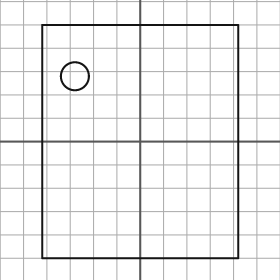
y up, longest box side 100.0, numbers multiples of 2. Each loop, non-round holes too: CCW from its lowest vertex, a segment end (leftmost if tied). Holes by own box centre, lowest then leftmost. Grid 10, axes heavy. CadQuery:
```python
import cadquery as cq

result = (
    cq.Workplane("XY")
    .moveTo(-42.0, -50.0)
    .lineTo(42.0, -50.0)
    .lineTo(42.0, 50.0)
    .lineTo(-42.0, 50.0)
    .close()
    .moveTo(-28.0, 28.0)
    .circle(6.0)
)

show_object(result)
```